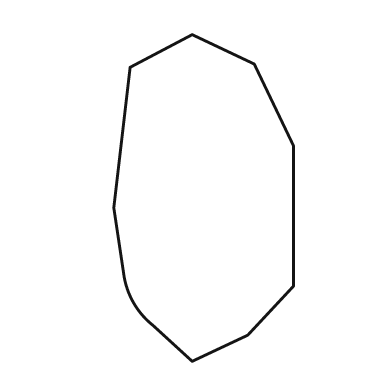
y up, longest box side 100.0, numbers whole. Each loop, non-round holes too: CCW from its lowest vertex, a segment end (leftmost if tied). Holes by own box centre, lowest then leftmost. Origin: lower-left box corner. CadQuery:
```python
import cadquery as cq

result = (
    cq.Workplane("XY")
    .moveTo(24.0, 0.0)
    .lineTo(41.0, 8.0)
    .lineTo(55.0, 23.0)
    .lineTo(55.0, 66.0)
    .lineTo(43.0, 91.0)
    .lineTo(24.0, 100.0)
    .lineTo(5.0, 90.0)
    .lineTo(0.0, 47.0)
    .lineTo(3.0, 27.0)
    .threePointArc((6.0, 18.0), (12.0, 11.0))
    .close()
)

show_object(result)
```